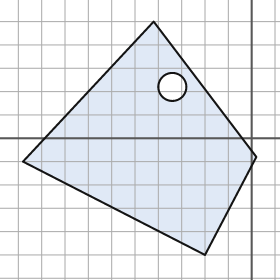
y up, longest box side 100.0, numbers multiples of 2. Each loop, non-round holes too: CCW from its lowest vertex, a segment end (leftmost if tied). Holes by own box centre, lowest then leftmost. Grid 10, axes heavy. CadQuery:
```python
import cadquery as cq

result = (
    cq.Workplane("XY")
    .moveTo(-20.0, -50.0)
    .lineTo(2.0, -8.0)
    .lineTo(-42.0, 50.0)
    .lineTo(-98.0, -10.0)
    .close()
    .moveTo(-34.0, 22.0)
    .circle(6.0)
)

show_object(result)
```